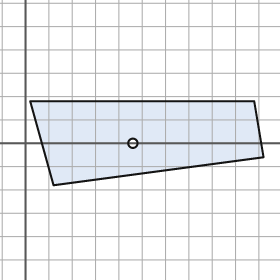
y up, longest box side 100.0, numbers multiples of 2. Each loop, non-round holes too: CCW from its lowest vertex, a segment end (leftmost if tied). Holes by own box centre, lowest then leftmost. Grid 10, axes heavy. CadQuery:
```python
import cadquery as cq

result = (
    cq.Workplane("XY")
    .moveTo(12.0, -18.0)
    .lineTo(102.0, -6.0)
    .lineTo(98.0, 18.0)
    .lineTo(2.0, 18.0)
    .close()
    .moveTo(46.0, 0.0)
    .circle(2.0)
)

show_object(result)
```